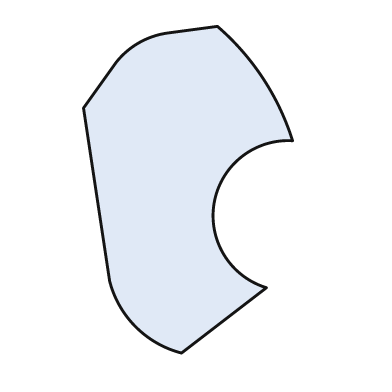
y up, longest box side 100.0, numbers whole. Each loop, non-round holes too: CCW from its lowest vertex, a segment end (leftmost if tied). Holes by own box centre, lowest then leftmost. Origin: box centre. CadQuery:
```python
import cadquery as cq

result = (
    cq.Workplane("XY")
    .moveTo(-2.0, -50.0)
    .lineTo(24.0, -30.0)
    .threePointArc((8.0, -4.0), (32.0, 15.0))
    .threePointArc((23.0, 34.0), (9.0, 50.0))
    .lineTo(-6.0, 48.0)
    .threePointArc((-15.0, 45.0), (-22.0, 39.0))
    .lineTo(-32.0, 25.0)
    .lineTo(-24.0, -28.0)
    .threePointArc((-16.0, -42.0), (-2.0, -50.0))
    .close()
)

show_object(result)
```